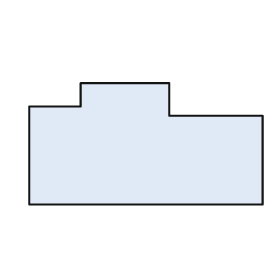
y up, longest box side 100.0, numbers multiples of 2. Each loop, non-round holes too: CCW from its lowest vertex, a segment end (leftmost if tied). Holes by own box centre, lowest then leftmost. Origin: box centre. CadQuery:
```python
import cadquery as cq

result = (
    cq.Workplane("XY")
    .moveTo(-50.0, -26.0)
    .lineTo(50.0, -26.0)
    .lineTo(50.0, 12.0)
    .lineTo(10.0, 12.0)
    .lineTo(10.0, 26.0)
    .lineTo(-28.0, 26.0)
    .lineTo(-28.0, 16.0)
    .lineTo(-50.0, 16.0)
    .close()
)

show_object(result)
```